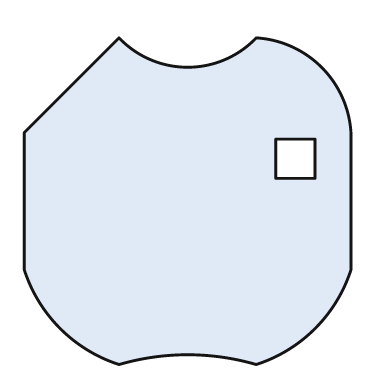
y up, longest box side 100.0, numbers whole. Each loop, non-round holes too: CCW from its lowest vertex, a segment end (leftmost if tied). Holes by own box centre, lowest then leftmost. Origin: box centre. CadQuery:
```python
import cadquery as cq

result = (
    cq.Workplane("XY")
    .moveTo(-21.0, -50.0)
    .threePointArc((0.0, -47.0), (21.0, -50.0))
    .threePointArc((39.0, -39.0), (50.0, -21.0))
    .lineTo(50.0, 21.0)
    .threePointArc((41.0, 41.0), (21.0, 50.0))
    .threePointArc((0.0, 41.0), (-21.0, 50.0))
    .lineTo(-50.0, 21.0)
    .lineTo(-50.0, -21.0)
    .threePointArc((-39.0, -39.0), (-21.0, -50.0))
    .close()
    .moveTo(27.0, 7.0)
    .lineTo(39.0, 7.0)
    .lineTo(39.0, 19.0)
    .lineTo(27.0, 19.0)
    .close()
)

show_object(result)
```